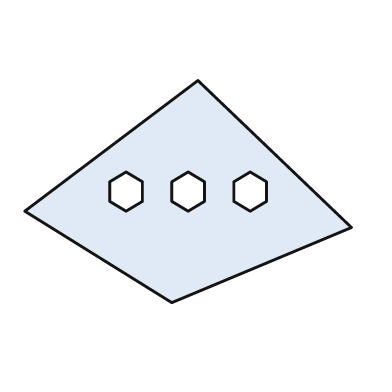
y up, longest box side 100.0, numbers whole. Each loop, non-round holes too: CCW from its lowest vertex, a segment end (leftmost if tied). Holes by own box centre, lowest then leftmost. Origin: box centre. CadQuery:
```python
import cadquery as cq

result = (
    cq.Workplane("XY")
    .moveTo(-5.0, -34.0)
    .lineTo(50.0, -11.0)
    .lineTo(3.0, 34.0)
    .lineTo(-50.0, -6.0)
    .close()
    .moveTo(-19.0, -6.0)
    .lineTo(-14.0, -3.0)
    .lineTo(-14.0, 3.0)
    .lineTo(-19.0, 6.0)
    .lineTo(-24.0, 3.0)
    .lineTo(-24.0, -3.0)
    .close()
    .moveTo(0.0, -6.0)
    .lineTo(5.0, -3.0)
    .lineTo(5.0, 3.0)
    .lineTo(0.0, 6.0)
    .lineTo(-5.0, 3.0)
    .lineTo(-5.0, -3.0)
    .close()
    .moveTo(19.0, -6.0)
    .lineTo(24.0, -3.0)
    .lineTo(24.0, 3.0)
    .lineTo(19.0, 6.0)
    .lineTo(14.0, 3.0)
    .lineTo(14.0, -3.0)
    .close()
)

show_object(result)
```